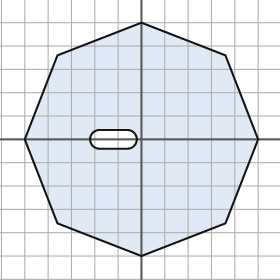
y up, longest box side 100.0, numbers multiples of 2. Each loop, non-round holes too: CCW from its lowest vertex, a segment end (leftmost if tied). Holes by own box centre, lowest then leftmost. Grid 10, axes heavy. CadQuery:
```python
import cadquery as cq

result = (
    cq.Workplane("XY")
    .moveTo(0.0, -50.0)
    .lineTo(36.0, -36.0)
    .lineTo(50.0, 0.0)
    .lineTo(36.0, 36.0)
    .lineTo(0.0, 50.0)
    .lineTo(-36.0, 36.0)
    .lineTo(-50.0, 0.0)
    .lineTo(-36.0, -36.0)
    .close()
    .moveTo(-18.0, -4.0)
    .lineTo(-6.0, -4.0)
    .threePointArc((-2.0, 0.0), (-6.0, 4.0))
    .lineTo(-18.0, 4.0)
    .threePointArc((-22.0, 0.0), (-18.0, -4.0))
    .close()
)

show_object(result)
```